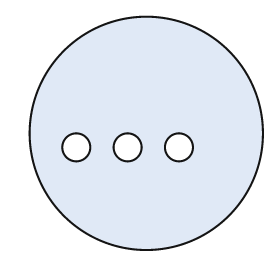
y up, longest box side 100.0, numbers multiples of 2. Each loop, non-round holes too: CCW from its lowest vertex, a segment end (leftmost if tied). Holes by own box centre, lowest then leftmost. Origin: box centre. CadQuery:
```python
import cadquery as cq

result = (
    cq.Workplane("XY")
    .moveTo(0.0, 0.0)
    .circle(50.0)
    .moveTo(-30.0, -6.0)
    .circle(6.0)
    .moveTo(-8.0, -6.0)
    .circle(6.0)
    .moveTo(14.0, -6.0)
    .circle(6.0)
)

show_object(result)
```